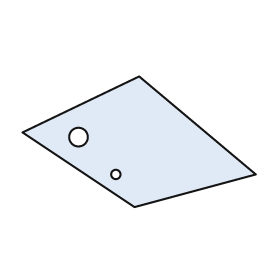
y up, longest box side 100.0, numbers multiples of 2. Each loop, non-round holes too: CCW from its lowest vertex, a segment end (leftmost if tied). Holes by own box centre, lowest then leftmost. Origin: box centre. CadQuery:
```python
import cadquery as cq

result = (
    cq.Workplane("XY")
    .moveTo(-2.0, -28.0)
    .lineTo(50.0, -14.0)
    .lineTo(0.0, 28.0)
    .lineTo(-50.0, 4.0)
    .close()
    .moveTo(-10.0, -14.0)
    .circle(2.0)
    .moveTo(-26.0, 2.0)
    .circle(4.0)
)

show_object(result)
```